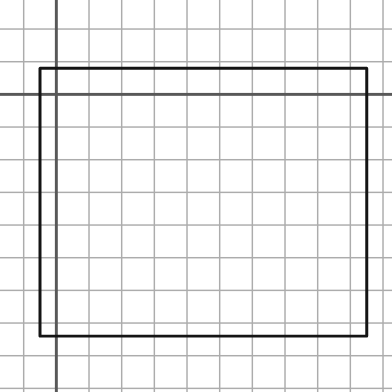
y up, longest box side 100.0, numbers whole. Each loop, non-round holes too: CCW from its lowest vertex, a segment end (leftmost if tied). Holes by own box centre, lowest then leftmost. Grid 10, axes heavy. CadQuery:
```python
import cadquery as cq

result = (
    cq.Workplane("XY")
    .moveTo(-5.0, -74.0)
    .lineTo(95.0, -74.0)
    .lineTo(95.0, 8.0)
    .lineTo(-5.0, 8.0)
    .close()
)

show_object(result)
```